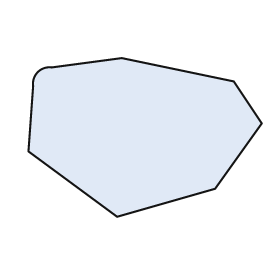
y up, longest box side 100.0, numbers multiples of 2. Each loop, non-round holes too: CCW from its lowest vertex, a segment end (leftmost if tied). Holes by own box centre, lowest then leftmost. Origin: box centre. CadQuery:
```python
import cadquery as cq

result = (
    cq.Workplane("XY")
    .moveTo(-12.0, -34.0)
    .lineTo(30.0, -22.0)
    .lineTo(50.0, 6.0)
    .lineTo(38.0, 24.0)
    .lineTo(-10.0, 34.0)
    .lineTo(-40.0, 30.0)
    .threePointArc((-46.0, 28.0), (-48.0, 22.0))
    .lineTo(-50.0, -6.0)
    .close()
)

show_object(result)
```